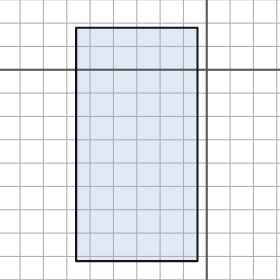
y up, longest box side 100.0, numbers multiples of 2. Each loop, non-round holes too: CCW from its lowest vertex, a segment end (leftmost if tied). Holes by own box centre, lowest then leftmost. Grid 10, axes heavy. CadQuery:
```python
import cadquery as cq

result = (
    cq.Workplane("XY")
    .moveTo(-56.0, -82.0)
    .lineTo(-4.0, -82.0)
    .lineTo(-4.0, 18.0)
    .lineTo(-56.0, 18.0)
    .close()
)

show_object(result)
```